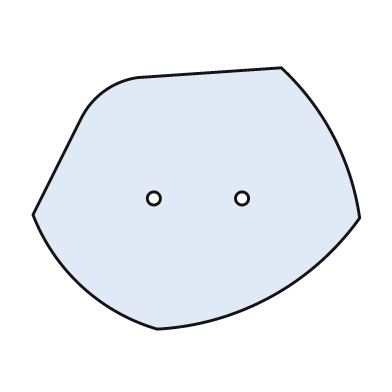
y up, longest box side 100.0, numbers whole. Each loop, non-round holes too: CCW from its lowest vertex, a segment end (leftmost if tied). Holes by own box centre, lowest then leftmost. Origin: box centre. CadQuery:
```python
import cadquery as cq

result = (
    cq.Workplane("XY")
    .moveTo(-12.0, -40.0)
    .threePointArc((23.0, -30.0), (50.0, -6.0))
    .threePointArc((42.0, 19.0), (26.0, 40.0))
    .lineTo(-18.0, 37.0)
    .threePointArc((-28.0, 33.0), (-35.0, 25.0))
    .lineTo(-50.0, -5.0)
    .threePointArc((-35.0, -27.0), (-12.0, -40.0))
    .close()
    .moveTo(-13.0, 0.0)
    .circle(2.0)
    .moveTo(14.0, 0.0)
    .circle(2.0)
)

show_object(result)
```